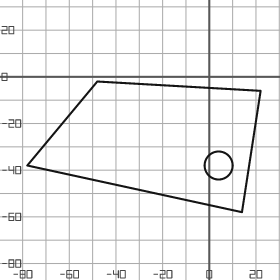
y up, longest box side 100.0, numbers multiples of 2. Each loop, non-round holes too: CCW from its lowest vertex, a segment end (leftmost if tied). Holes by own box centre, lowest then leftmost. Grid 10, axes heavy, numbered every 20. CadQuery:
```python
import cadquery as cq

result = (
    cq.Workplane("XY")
    .moveTo(14.0, -58.0)
    .lineTo(22.0, -6.0)
    .lineTo(-48.0, -2.0)
    .lineTo(-78.0, -38.0)
    .close()
    .moveTo(4.0, -38.0)
    .circle(6.0)
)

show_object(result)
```